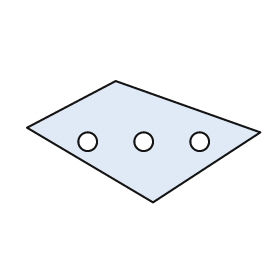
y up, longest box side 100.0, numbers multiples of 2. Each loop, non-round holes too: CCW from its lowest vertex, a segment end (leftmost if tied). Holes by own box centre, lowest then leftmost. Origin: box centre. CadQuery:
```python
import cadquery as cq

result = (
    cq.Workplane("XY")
    .moveTo(4.0, -26.0)
    .lineTo(50.0, 4.0)
    .lineTo(-12.0, 26.0)
    .lineTo(-50.0, 6.0)
    .close()
    .moveTo(-24.0, 0.0)
    .circle(4.0)
    .moveTo(0.0, 0.0)
    .circle(4.0)
    .moveTo(24.0, 0.0)
    .circle(4.0)
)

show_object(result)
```